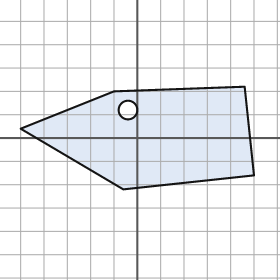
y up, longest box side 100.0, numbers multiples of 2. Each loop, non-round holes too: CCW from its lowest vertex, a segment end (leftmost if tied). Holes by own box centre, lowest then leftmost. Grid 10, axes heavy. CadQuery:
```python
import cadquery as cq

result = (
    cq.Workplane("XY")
    .moveTo(-6.0, -22.0)
    .lineTo(50.0, -16.0)
    .lineTo(46.0, 22.0)
    .lineTo(-10.0, 20.0)
    .lineTo(-50.0, 4.0)
    .close()
    .moveTo(-4.0, 12.0)
    .circle(4.0)
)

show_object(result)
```